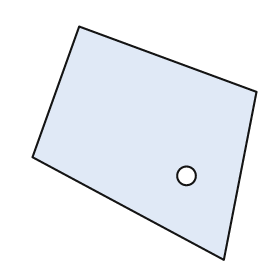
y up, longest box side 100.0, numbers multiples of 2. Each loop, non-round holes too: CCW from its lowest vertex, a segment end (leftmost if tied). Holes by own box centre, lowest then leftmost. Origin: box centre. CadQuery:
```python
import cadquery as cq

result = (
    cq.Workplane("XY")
    .moveTo(34.0, -50.0)
    .lineTo(48.0, 22.0)
    .lineTo(-28.0, 50.0)
    .lineTo(-48.0, -6.0)
    .close()
    .moveTo(18.0, -14.0)
    .circle(4.0)
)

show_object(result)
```